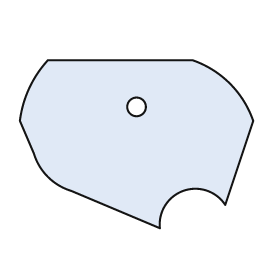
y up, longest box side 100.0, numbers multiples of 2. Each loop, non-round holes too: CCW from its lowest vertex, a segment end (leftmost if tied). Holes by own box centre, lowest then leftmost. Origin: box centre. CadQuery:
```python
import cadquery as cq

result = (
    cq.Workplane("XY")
    .moveTo(10.0, -36.0)
    .threePointArc((20.0, -20.0), (38.0, -26.0))
    .lineTo(50.0, 10.0)
    .threePointArc((40.0, 26.0), (24.0, 36.0))
    .lineTo(-38.0, 36.0)
    .threePointArc((-46.0, 24.0), (-50.0, 10.0))
    .lineTo(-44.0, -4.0)
    .threePointArc((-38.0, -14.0), (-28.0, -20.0))
    .close()
    .moveTo(0.0, 16.0)
    .circle(4.0)
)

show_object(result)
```